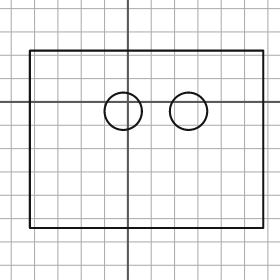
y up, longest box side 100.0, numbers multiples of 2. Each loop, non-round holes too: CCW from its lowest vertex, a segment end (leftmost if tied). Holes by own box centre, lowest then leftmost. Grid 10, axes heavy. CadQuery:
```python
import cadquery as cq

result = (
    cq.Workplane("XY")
    .moveTo(-42.0, -54.0)
    .lineTo(58.0, -54.0)
    .lineTo(58.0, 22.0)
    .lineTo(-42.0, 22.0)
    .close()
    .moveTo(-2.0, -4.0)
    .circle(8.0)
    .moveTo(26.0, -4.0)
    .circle(8.0)
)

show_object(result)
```